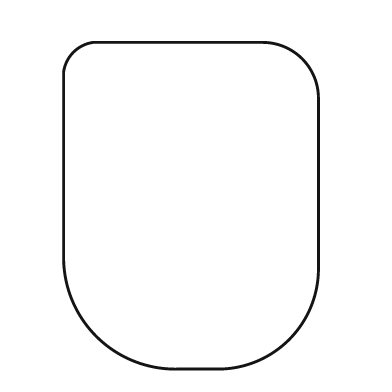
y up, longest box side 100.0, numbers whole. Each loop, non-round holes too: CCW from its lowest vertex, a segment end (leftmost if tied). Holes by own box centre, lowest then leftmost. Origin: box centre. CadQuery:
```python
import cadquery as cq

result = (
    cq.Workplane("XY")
    .moveTo(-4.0, -50.0)
    .lineTo(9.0, -50.0)
    .threePointArc((30.0, -41.0), (39.0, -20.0))
    .lineTo(39.0, 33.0)
    .threePointArc((34.0, 45.0), (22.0, 50.0))
    .lineTo(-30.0, 50.0)
    .threePointArc((-36.0, 47.0), (-39.0, 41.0))
    .lineTo(-39.0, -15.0)
    .threePointArc((-29.0, -40.0), (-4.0, -50.0))
    .close()
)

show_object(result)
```